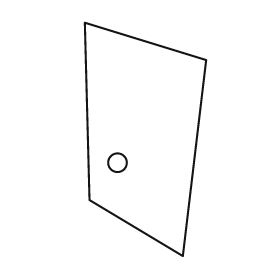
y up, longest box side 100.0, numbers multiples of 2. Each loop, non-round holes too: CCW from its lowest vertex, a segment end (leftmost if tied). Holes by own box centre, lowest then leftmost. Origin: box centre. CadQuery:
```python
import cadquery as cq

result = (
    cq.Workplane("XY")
    .moveTo(16.0, -50.0)
    .lineTo(26.0, 34.0)
    .lineTo(-26.0, 50.0)
    .lineTo(-24.0, -26.0)
    .close()
    .moveTo(-12.0, -10.0)
    .circle(4.0)
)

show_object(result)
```